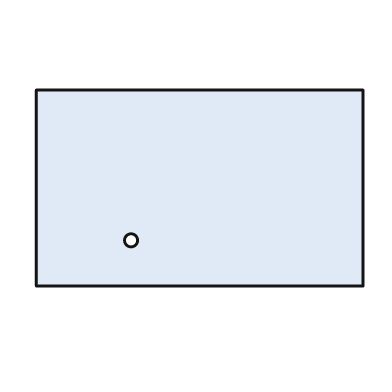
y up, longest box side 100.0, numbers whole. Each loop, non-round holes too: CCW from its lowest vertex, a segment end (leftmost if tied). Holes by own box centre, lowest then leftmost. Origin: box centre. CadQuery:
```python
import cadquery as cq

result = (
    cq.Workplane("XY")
    .moveTo(-50.0, -30.0)
    .lineTo(50.0, -30.0)
    .lineTo(50.0, 30.0)
    .lineTo(-50.0, 30.0)
    .close()
    .moveTo(-21.0, -16.0)
    .circle(2.0)
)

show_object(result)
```